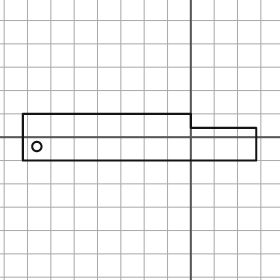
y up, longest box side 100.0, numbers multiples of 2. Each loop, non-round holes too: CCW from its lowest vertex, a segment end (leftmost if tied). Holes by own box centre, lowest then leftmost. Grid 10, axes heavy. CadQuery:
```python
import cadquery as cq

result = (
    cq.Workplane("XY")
    .moveTo(-72.0, -10.0)
    .lineTo(28.0, -10.0)
    .lineTo(28.0, 4.0)
    .lineTo(0.0, 4.0)
    .lineTo(0.0, 10.0)
    .lineTo(-72.0, 10.0)
    .close()
    .moveTo(-66.0, -4.0)
    .circle(2.0)
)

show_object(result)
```